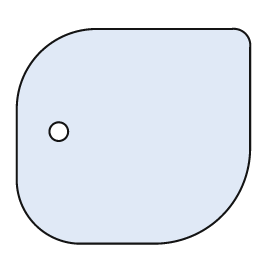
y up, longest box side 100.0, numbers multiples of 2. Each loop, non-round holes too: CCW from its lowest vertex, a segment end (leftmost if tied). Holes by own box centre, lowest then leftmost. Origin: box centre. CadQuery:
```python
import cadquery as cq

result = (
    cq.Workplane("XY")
    .moveTo(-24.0, -46.0)
    .lineTo(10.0, -46.0)
    .threePointArc((38.0, -34.0), (50.0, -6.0))
    .lineTo(50.0, 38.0)
    .threePointArc((48.0, 44.0), (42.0, 46.0))
    .lineTo(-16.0, 46.0)
    .threePointArc((-40.0, 36.0), (-50.0, 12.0))
    .lineTo(-50.0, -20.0)
    .threePointArc((-42.0, -38.0), (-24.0, -46.0))
    .close()
    .moveTo(-32.0, 2.0)
    .circle(4.0)
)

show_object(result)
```